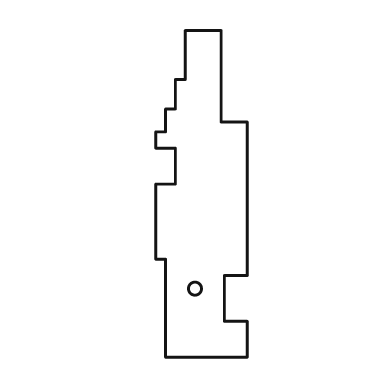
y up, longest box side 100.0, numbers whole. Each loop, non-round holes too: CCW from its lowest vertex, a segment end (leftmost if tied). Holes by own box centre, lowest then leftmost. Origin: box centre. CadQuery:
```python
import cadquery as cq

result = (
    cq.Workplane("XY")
    .moveTo(-11.0, -50.0)
    .lineTo(14.0, -50.0)
    .lineTo(14.0, -39.0)
    .lineTo(7.0, -39.0)
    .lineTo(7.0, -25.0)
    .lineTo(14.0, -25.0)
    .lineTo(14.0, 22.0)
    .lineTo(6.0, 22.0)
    .lineTo(6.0, 50.0)
    .lineTo(-5.0, 50.0)
    .lineTo(-5.0, 35.0)
    .lineTo(-8.0, 35.0)
    .lineTo(-8.0, 26.0)
    .lineTo(-11.0, 26.0)
    .lineTo(-11.0, 19.0)
    .lineTo(-14.0, 19.0)
    .lineTo(-14.0, 14.0)
    .lineTo(-8.0, 14.0)
    .lineTo(-8.0, 3.0)
    .lineTo(-14.0, 3.0)
    .lineTo(-14.0, -20.0)
    .lineTo(-11.0, -20.0)
    .close()
    .moveTo(-2.0, -29.0)
    .circle(2.0)
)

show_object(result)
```